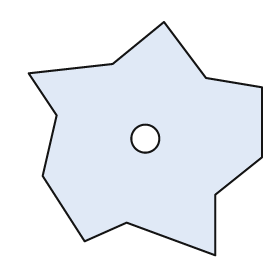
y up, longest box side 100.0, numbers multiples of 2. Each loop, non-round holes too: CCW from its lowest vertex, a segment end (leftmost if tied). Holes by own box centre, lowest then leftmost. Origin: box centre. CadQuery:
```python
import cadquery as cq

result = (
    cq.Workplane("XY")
    .moveTo(30.0, -50.0)
    .lineTo(30.0, -24.0)
    .lineTo(50.0, -8.0)
    .lineTo(50.0, 22.0)
    .lineTo(26.0, 26.0)
    .lineTo(8.0, 50.0)
    .lineTo(-14.0, 32.0)
    .lineTo(-50.0, 28.0)
    .lineTo(-38.0, 10.0)
    .lineTo(-44.0, -16.0)
    .lineTo(-26.0, -44.0)
    .lineTo(-8.0, -36.0)
    .close()
    .moveTo(0.0, 0.0)
    .circle(6.0)
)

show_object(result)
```